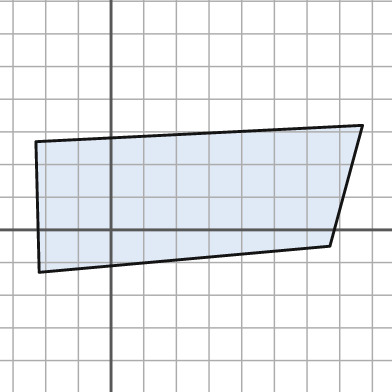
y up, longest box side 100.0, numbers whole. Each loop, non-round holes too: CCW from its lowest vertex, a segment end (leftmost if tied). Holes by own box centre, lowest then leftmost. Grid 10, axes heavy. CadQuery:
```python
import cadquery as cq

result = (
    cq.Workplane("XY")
    .moveTo(-22.0, -13.0)
    .lineTo(67.0, -5.0)
    .lineTo(77.0, 32.0)
    .lineTo(-23.0, 27.0)
    .close()
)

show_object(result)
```